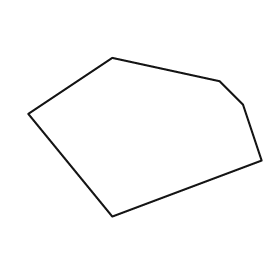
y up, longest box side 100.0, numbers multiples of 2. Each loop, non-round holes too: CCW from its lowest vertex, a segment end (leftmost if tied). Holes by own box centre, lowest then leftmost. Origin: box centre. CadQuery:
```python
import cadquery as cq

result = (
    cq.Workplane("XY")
    .moveTo(-14.0, -34.0)
    .lineTo(50.0, -10.0)
    .lineTo(42.0, 14.0)
    .lineTo(32.0, 24.0)
    .lineTo(-14.0, 34.0)
    .lineTo(-50.0, 10.0)
    .close()
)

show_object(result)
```